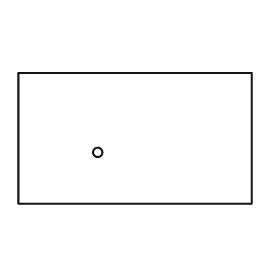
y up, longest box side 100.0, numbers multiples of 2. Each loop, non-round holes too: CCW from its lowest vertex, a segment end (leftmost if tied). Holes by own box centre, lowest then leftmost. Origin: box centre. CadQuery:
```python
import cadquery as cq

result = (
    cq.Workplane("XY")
    .moveTo(-50.0, -28.0)
    .lineTo(50.0, -28.0)
    .lineTo(50.0, 28.0)
    .lineTo(-50.0, 28.0)
    .close()
    .moveTo(-16.0, -6.0)
    .circle(2.0)
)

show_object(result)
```